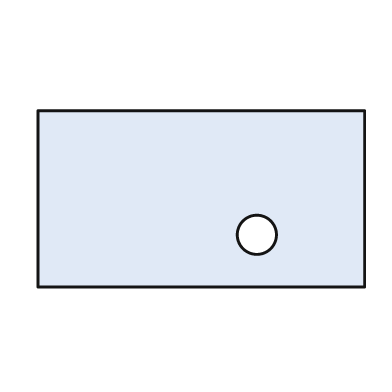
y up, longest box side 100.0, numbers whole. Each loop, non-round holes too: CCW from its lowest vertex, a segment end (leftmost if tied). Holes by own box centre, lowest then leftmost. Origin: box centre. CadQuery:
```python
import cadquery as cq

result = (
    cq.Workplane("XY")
    .moveTo(-50.0, -27.0)
    .lineTo(50.0, -27.0)
    .lineTo(50.0, 27.0)
    .lineTo(-50.0, 27.0)
    .close()
    .moveTo(17.0, -11.0)
    .circle(6.0)
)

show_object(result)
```